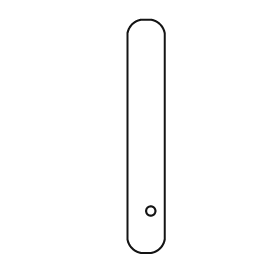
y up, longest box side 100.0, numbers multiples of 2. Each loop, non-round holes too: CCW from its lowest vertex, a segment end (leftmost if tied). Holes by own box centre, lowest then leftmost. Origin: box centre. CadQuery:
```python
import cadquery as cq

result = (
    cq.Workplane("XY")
    .moveTo(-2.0, -50.0)
    .lineTo(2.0, -50.0)
    .threePointArc((6.0, -48.0), (8.0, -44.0))
    .lineTo(8.0, 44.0)
    .threePointArc((6.0, 48.0), (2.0, 50.0))
    .lineTo(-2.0, 50.0)
    .threePointArc((-6.0, 48.0), (-8.0, 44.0))
    .lineTo(-8.0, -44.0)
    .threePointArc((-6.0, -48.0), (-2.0, -50.0))
    .close()
    .moveTo(2.0, -32.0)
    .circle(2.0)
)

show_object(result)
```